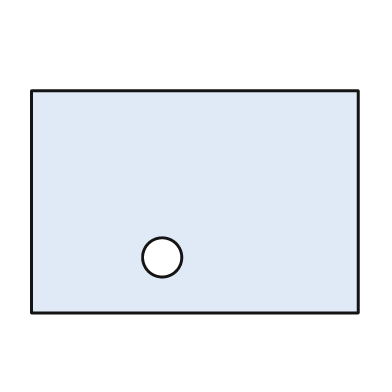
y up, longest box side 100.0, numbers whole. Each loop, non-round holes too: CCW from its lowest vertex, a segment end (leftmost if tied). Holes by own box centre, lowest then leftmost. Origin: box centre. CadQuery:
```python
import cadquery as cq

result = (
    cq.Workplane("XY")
    .moveTo(-50.0, -34.0)
    .lineTo(50.0, -34.0)
    .lineTo(50.0, 34.0)
    .lineTo(-50.0, 34.0)
    .close()
    .moveTo(-10.0, -17.0)
    .circle(6.0)
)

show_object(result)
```